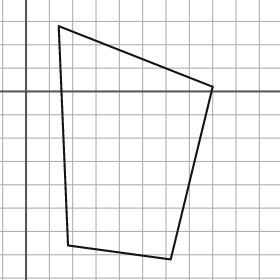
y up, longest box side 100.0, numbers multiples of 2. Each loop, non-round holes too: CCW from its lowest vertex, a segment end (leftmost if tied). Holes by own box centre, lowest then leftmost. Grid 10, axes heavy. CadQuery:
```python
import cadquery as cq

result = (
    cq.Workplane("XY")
    .moveTo(62.0, -72.0)
    .lineTo(80.0, 2.0)
    .lineTo(14.0, 28.0)
    .lineTo(18.0, -66.0)
    .close()
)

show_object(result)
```